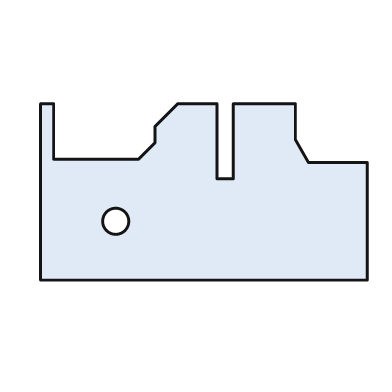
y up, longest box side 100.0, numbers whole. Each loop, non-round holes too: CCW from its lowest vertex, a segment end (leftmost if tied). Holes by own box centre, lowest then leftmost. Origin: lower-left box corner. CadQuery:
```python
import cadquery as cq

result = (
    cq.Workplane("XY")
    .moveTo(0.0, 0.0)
    .lineTo(100.0, 0.0)
    .lineTo(100.0, 36.0)
    .lineTo(82.0, 36.0)
    .lineTo(78.0, 43.0)
    .lineTo(78.0, 54.0)
    .lineTo(59.0, 54.0)
    .lineTo(59.0, 31.0)
    .lineTo(54.0, 31.0)
    .lineTo(54.0, 54.0)
    .lineTo(42.0, 54.0)
    .lineTo(35.0, 47.0)
    .lineTo(35.0, 42.0)
    .lineTo(30.0, 37.0)
    .lineTo(4.0, 37.0)
    .lineTo(4.0, 54.0)
    .lineTo(0.0, 54.0)
    .close()
    .moveTo(23.0, 18.0)
    .circle(4.0)
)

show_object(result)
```